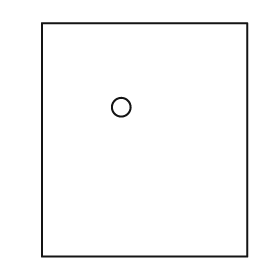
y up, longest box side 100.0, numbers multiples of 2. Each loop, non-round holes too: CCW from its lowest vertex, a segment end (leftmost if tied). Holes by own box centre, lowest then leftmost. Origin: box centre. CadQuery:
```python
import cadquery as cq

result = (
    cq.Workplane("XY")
    .moveTo(-44.0, -50.0)
    .lineTo(44.0, -50.0)
    .lineTo(44.0, 50.0)
    .lineTo(-44.0, 50.0)
    .close()
    .moveTo(-10.0, 14.0)
    .circle(4.0)
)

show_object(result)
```